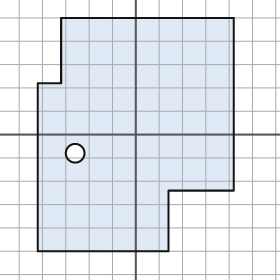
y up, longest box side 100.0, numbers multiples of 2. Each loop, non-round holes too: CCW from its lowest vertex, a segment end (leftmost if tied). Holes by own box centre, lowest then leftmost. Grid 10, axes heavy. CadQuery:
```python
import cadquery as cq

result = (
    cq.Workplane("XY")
    .moveTo(-42.0, -50.0)
    .lineTo(14.0, -50.0)
    .lineTo(14.0, -24.0)
    .lineTo(42.0, -24.0)
    .lineTo(42.0, 50.0)
    .lineTo(-32.0, 50.0)
    .lineTo(-32.0, 22.0)
    .lineTo(-42.0, 22.0)
    .close()
    .moveTo(-26.0, -8.0)
    .circle(4.0)
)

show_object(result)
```